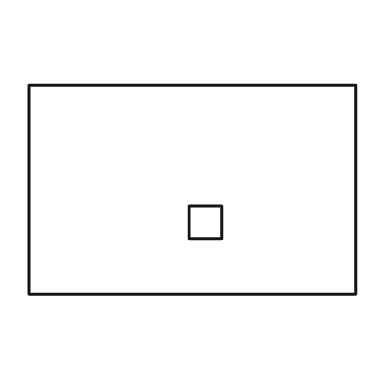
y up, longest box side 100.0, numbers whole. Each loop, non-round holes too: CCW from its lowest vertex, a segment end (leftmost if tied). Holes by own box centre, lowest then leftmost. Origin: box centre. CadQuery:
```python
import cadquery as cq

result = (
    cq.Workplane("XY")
    .moveTo(-50.0, -32.0)
    .lineTo(50.0, -32.0)
    .lineTo(50.0, 32.0)
    .lineTo(-50.0, 32.0)
    .close()
    .moveTo(-1.0, -15.0)
    .lineTo(9.0, -15.0)
    .lineTo(9.0, -5.0)
    .lineTo(-1.0, -5.0)
    .close()
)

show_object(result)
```